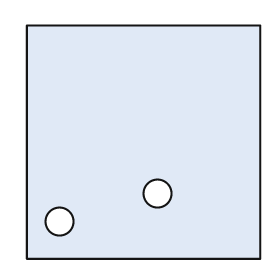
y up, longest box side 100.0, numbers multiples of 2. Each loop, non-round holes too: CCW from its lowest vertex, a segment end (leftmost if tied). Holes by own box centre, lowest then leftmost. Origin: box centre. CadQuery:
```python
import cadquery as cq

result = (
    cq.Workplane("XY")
    .moveTo(-50.0, -50.0)
    .lineTo(50.0, -50.0)
    .lineTo(50.0, 50.0)
    .lineTo(-50.0, 50.0)
    .close()
    .moveTo(-36.0, -34.0)
    .circle(6.0)
    .moveTo(6.0, -22.0)
    .circle(6.0)
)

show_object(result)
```